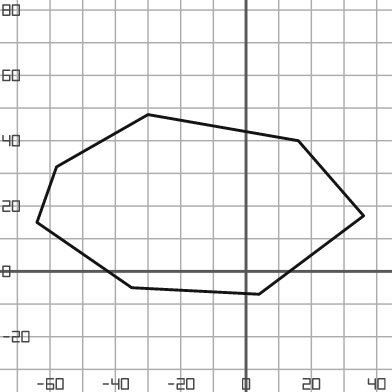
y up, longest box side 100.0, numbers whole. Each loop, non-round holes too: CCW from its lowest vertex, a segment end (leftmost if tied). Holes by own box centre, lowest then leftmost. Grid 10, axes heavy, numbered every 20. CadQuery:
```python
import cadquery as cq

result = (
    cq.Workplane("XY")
    .moveTo(4.0, -7.0)
    .lineTo(36.0, 17.0)
    .lineTo(16.0, 40.0)
    .lineTo(-30.0, 48.0)
    .lineTo(-58.0, 32.0)
    .lineTo(-64.0, 15.0)
    .lineTo(-35.0, -5.0)
    .close()
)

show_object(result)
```